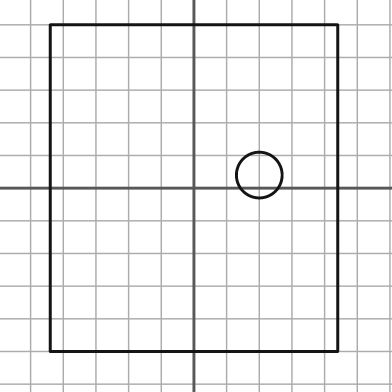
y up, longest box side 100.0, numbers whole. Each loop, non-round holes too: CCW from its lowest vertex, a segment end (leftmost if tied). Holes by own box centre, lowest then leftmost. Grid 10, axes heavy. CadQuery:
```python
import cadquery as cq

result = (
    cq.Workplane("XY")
    .moveTo(-44.0, -50.0)
    .lineTo(44.0, -50.0)
    .lineTo(44.0, 50.0)
    .lineTo(-44.0, 50.0)
    .close()
    .moveTo(20.0, 4.0)
    .circle(7.0)
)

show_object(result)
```